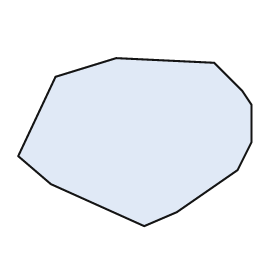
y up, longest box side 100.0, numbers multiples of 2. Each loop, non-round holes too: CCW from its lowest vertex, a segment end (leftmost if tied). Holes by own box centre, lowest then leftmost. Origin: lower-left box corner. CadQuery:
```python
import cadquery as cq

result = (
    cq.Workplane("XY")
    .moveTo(54.0, 0.0)
    .lineTo(68.0, 6.0)
    .lineTo(94.0, 24.0)
    .lineTo(100.0, 36.0)
    .lineTo(100.0, 52.0)
    .lineTo(96.0, 58.0)
    .lineTo(84.0, 70.0)
    .lineTo(42.0, 72.0)
    .lineTo(16.0, 64.0)
    .lineTo(0.0, 30.0)
    .lineTo(14.0, 18.0)
    .close()
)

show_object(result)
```